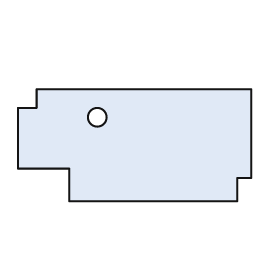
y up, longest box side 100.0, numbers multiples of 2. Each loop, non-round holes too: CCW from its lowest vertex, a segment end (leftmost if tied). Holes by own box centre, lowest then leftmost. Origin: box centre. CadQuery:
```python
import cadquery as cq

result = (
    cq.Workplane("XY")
    .moveTo(-28.0, -24.0)
    .lineTo(44.0, -24.0)
    .lineTo(44.0, -14.0)
    .lineTo(50.0, -14.0)
    .lineTo(50.0, 24.0)
    .lineTo(-42.0, 24.0)
    .lineTo(-42.0, 16.0)
    .lineTo(-50.0, 16.0)
    .lineTo(-50.0, -10.0)
    .lineTo(-28.0, -10.0)
    .close()
    .moveTo(-16.0, 12.0)
    .circle(4.0)
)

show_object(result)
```